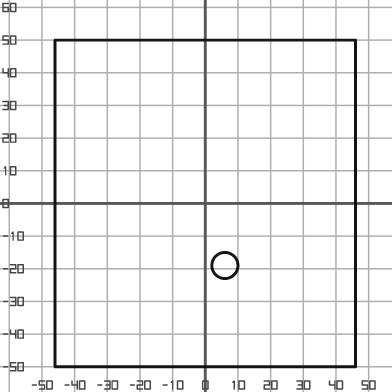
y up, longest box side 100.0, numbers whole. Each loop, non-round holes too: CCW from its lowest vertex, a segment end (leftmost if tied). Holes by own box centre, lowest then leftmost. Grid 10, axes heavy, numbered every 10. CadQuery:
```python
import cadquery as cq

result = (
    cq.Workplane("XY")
    .moveTo(-46.0, -50.0)
    .lineTo(46.0, -50.0)
    .lineTo(46.0, 50.0)
    .lineTo(-46.0, 50.0)
    .close()
    .moveTo(6.0, -19.0)
    .circle(4.0)
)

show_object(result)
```